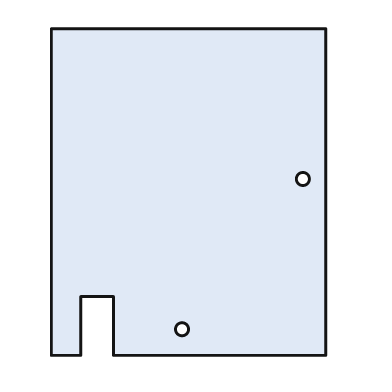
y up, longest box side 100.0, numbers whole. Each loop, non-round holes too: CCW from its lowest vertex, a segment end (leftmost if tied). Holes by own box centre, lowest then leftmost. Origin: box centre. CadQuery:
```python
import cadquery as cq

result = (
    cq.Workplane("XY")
    .moveTo(-42.0, -50.0)
    .lineTo(-33.0, -50.0)
    .lineTo(-33.0, -32.0)
    .lineTo(-23.0, -32.0)
    .lineTo(-23.0, -50.0)
    .lineTo(42.0, -50.0)
    .lineTo(42.0, 50.0)
    .lineTo(-42.0, 50.0)
    .close()
    .moveTo(-2.0, -42.0)
    .circle(2.0)
    .moveTo(35.0, 4.0)
    .circle(2.0)
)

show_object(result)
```